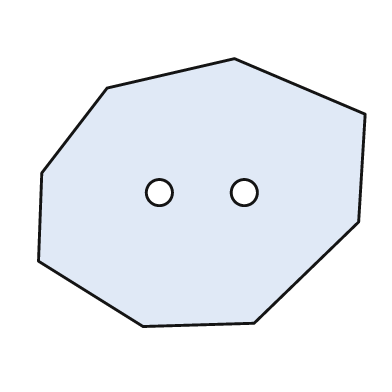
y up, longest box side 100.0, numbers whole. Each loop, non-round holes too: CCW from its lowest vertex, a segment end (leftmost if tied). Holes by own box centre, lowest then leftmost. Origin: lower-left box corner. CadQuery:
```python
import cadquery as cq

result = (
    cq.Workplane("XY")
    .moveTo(32.0, 0.0)
    .lineTo(66.0, 1.0)
    .lineTo(98.0, 32.0)
    .lineTo(100.0, 65.0)
    .lineTo(60.0, 82.0)
    .lineTo(21.0, 73.0)
    .lineTo(1.0, 47.0)
    .lineTo(0.0, 20.0)
    .close()
    .moveTo(37.0, 41.0)
    .circle(4.0)
    .moveTo(63.0, 41.0)
    .circle(4.0)
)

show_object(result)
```